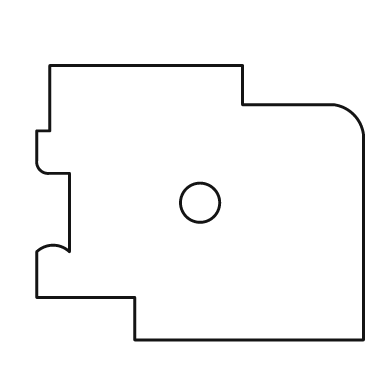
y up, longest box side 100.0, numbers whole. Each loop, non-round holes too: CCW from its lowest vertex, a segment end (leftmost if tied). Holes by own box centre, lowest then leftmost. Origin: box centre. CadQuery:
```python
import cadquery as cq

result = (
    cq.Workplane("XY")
    .moveTo(-20.0, -42.0)
    .lineTo(50.0, -42.0)
    .lineTo(50.0, 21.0)
    .threePointArc((47.0, 27.0), (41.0, 30.0))
    .lineTo(13.0, 30.0)
    .lineTo(13.0, 42.0)
    .lineTo(-46.0, 42.0)
    .lineTo(-46.0, 22.0)
    .lineTo(-50.0, 22.0)
    .lineTo(-50.0, 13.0)
    .threePointArc((-49.0, 10.0), (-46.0, 9.0))
    .lineTo(-40.0, 9.0)
    .lineTo(-40.0, -15.0)
    .threePointArc((-45.0, -13.0), (-50.0, -15.0))
    .lineTo(-50.0, -29.0)
    .lineTo(-20.0, -29.0)
    .close()
    .moveTo(0.0, 0.0)
    .circle(6.0)
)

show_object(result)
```